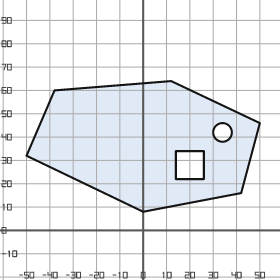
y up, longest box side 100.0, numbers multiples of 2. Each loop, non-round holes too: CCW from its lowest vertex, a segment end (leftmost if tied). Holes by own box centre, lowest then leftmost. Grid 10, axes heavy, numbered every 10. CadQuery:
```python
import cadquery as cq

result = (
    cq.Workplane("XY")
    .moveTo(0.0, 8.0)
    .lineTo(42.0, 16.0)
    .lineTo(50.0, 46.0)
    .lineTo(12.0, 64.0)
    .lineTo(-38.0, 60.0)
    .lineTo(-50.0, 32.0)
    .close()
    .moveTo(14.0, 22.0)
    .lineTo(26.0, 22.0)
    .lineTo(26.0, 34.0)
    .lineTo(14.0, 34.0)
    .close()
    .moveTo(34.0, 42.0)
    .circle(4.0)
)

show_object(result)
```